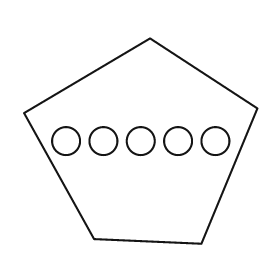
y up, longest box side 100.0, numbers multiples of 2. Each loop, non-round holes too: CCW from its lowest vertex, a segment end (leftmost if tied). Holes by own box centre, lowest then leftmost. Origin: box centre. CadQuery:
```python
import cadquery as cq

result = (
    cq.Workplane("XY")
    .moveTo(26.0, -44.0)
    .lineTo(50.0, 14.0)
    .lineTo(4.0, 44.0)
    .lineTo(-50.0, 12.0)
    .lineTo(-20.0, -42.0)
    .close()
    .moveTo(-32.0, 0.0)
    .circle(6.0)
    .moveTo(-16.0, 0.0)
    .circle(6.0)
    .moveTo(0.0, 0.0)
    .circle(6.0)
    .moveTo(16.0, 0.0)
    .circle(6.0)
    .moveTo(32.0, 0.0)
    .circle(6.0)
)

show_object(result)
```